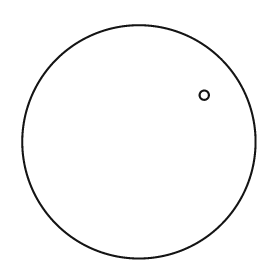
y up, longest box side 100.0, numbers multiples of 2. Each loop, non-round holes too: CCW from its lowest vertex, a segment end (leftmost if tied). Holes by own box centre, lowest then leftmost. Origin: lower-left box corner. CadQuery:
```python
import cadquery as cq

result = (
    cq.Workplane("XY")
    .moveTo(50.0, 50.0)
    .circle(50.0)
    .moveTo(78.0, 70.0)
    .circle(2.0)
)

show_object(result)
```